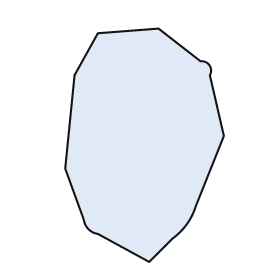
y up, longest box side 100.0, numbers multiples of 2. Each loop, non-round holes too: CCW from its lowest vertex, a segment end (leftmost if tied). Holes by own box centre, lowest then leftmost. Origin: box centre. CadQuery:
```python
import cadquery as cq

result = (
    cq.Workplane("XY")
    .moveTo(2.0, -50.0)
    .lineTo(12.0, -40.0)
    .threePointArc((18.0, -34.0), (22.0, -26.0))
    .lineTo(34.0, 4.0)
    .lineTo(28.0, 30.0)
    .threePointArc((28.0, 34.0), (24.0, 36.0))
    .lineTo(6.0, 50.0)
    .lineTo(-20.0, 48.0)
    .lineTo(-30.0, 30.0)
    .lineTo(-34.0, -10.0)
    .lineTo(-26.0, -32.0)
    .threePointArc((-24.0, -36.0), (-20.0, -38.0))
    .close()
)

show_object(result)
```